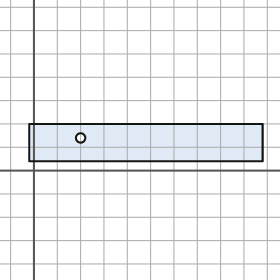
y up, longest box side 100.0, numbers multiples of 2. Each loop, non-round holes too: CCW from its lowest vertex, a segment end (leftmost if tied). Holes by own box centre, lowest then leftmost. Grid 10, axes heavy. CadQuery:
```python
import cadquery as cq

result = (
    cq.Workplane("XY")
    .moveTo(-2.0, 4.0)
    .lineTo(98.0, 4.0)
    .lineTo(98.0, 20.0)
    .lineTo(-2.0, 20.0)
    .close()
    .moveTo(20.0, 14.0)
    .circle(2.0)
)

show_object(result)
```